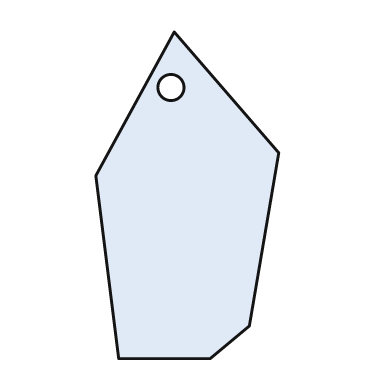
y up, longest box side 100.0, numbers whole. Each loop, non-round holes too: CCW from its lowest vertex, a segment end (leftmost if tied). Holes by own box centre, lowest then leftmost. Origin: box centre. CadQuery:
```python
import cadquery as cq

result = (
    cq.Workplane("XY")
    .moveTo(-21.0, -50.0)
    .lineTo(7.0, -50.0)
    .lineTo(19.0, -40.0)
    .lineTo(28.0, 13.0)
    .lineTo(-4.0, 50.0)
    .lineTo(-28.0, 6.0)
    .close()
    .moveTo(-5.0, 33.0)
    .circle(4.0)
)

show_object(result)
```